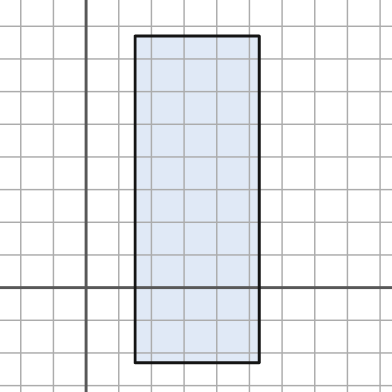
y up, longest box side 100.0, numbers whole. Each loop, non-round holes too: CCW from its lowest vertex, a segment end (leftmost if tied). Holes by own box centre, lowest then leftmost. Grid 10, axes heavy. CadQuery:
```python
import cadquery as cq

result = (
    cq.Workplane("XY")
    .moveTo(15.0, -23.0)
    .lineTo(53.0, -23.0)
    .lineTo(53.0, 77.0)
    .lineTo(15.0, 77.0)
    .close()
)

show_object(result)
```